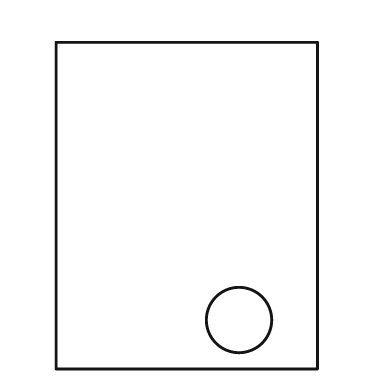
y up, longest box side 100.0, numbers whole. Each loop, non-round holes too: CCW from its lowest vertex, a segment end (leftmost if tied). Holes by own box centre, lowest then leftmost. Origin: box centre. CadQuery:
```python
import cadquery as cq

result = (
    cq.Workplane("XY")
    .moveTo(-40.0, -50.0)
    .lineTo(40.0, -50.0)
    .lineTo(40.0, 50.0)
    .lineTo(-40.0, 50.0)
    .close()
    .moveTo(16.0, -35.0)
    .circle(10.0)
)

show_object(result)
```